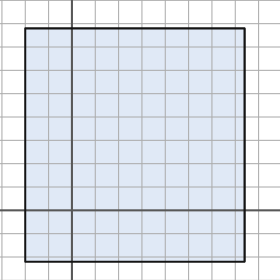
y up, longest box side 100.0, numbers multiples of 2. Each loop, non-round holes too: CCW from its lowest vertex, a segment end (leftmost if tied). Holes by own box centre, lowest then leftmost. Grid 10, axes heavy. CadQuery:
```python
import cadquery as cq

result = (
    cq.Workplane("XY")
    .moveTo(-20.0, -22.0)
    .lineTo(74.0, -22.0)
    .lineTo(74.0, 78.0)
    .lineTo(-20.0, 78.0)
    .close()
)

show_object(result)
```